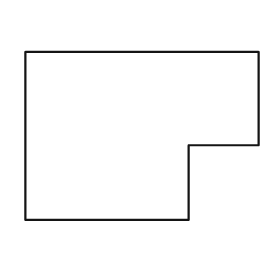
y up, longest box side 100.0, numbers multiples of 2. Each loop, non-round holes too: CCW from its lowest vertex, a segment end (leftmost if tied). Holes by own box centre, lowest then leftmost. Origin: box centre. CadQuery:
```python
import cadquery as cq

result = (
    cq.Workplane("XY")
    .moveTo(-50.0, -36.0)
    .lineTo(20.0, -36.0)
    .lineTo(20.0, -4.0)
    .lineTo(50.0, -4.0)
    .lineTo(50.0, 36.0)
    .lineTo(-50.0, 36.0)
    .close()
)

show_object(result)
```